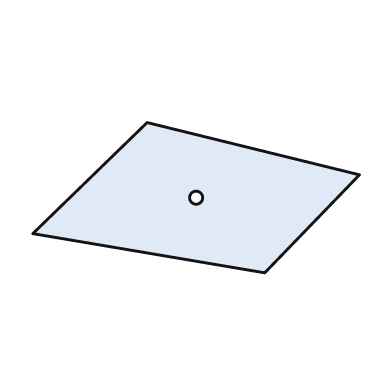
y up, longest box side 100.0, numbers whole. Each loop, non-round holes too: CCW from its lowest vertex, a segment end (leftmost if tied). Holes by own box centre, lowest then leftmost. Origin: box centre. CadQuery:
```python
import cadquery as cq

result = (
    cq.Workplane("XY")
    .moveTo(21.0, -23.0)
    .lineTo(50.0, 7.0)
    .lineTo(-15.0, 23.0)
    .lineTo(-50.0, -11.0)
    .close()
    .moveTo(0.0, 0.0)
    .circle(2.0)
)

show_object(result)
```